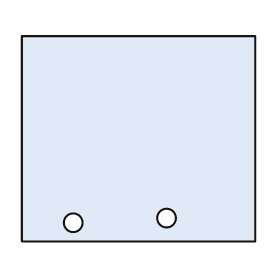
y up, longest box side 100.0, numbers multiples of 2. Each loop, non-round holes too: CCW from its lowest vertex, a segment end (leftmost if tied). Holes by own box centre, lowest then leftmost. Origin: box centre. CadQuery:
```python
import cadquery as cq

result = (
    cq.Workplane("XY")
    .moveTo(-50.0, -44.0)
    .lineTo(50.0, -44.0)
    .lineTo(50.0, 44.0)
    .lineTo(-50.0, 44.0)
    .close()
    .moveTo(-28.0, -36.0)
    .circle(4.0)
    .moveTo(12.0, -34.0)
    .circle(4.0)
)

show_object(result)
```